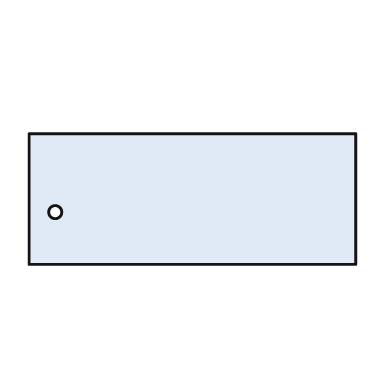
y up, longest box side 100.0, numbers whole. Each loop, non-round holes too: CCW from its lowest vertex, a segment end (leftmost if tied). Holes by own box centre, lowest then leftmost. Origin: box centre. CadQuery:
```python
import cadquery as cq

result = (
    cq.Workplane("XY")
    .moveTo(-50.0, -20.0)
    .lineTo(50.0, -20.0)
    .lineTo(50.0, 20.0)
    .lineTo(-50.0, 20.0)
    .close()
    .moveTo(-42.0, -4.0)
    .circle(2.0)
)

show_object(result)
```